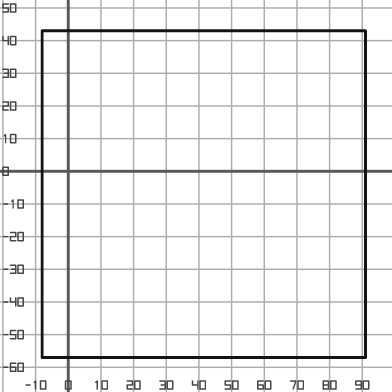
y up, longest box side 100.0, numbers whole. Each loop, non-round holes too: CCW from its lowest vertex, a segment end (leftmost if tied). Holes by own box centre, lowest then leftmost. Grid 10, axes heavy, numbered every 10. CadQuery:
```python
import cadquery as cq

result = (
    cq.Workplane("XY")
    .moveTo(-8.0, -57.0)
    .lineTo(91.0, -57.0)
    .lineTo(91.0, 43.0)
    .lineTo(-8.0, 43.0)
    .close()
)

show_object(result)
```